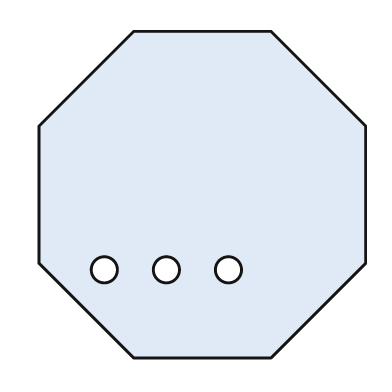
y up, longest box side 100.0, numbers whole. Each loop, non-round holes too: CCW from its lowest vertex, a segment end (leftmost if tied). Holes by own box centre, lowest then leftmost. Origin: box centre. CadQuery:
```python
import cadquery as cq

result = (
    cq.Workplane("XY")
    .moveTo(-21.0, -50.0)
    .lineTo(21.0, -50.0)
    .lineTo(50.0, -21.0)
    .lineTo(50.0, 21.0)
    .lineTo(21.0, 50.0)
    .lineTo(-21.0, 50.0)
    .lineTo(-50.0, 21.0)
    .lineTo(-50.0, -21.0)
    .close()
    .moveTo(-30.0, -23.0)
    .circle(4.0)
    .moveTo(-11.0, -23.0)
    .circle(4.0)
    .moveTo(8.0, -23.0)
    .circle(4.0)
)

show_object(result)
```